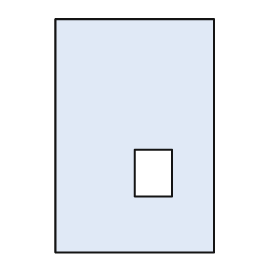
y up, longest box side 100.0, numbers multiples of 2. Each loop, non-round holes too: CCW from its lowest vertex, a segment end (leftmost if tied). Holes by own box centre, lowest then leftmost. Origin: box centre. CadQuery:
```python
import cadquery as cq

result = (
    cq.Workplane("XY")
    .moveTo(-34.0, -50.0)
    .lineTo(34.0, -50.0)
    .lineTo(34.0, 50.0)
    .lineTo(-34.0, 50.0)
    .close()
    .moveTo(0.0, -26.0)
    .lineTo(16.0, -26.0)
    .lineTo(16.0, -6.0)
    .lineTo(0.0, -6.0)
    .close()
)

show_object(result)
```